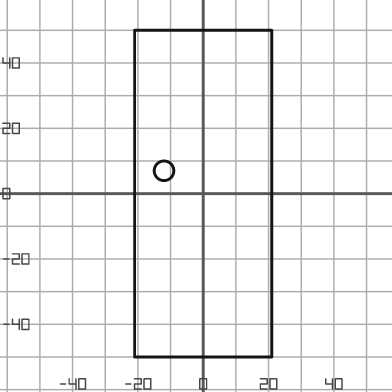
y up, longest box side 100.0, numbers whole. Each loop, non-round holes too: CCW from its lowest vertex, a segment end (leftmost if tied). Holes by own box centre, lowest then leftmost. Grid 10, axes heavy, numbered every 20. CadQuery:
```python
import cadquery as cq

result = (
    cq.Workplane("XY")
    .moveTo(-21.0, -50.0)
    .lineTo(21.0, -50.0)
    .lineTo(21.0, 50.0)
    .lineTo(-21.0, 50.0)
    .close()
    .moveTo(-12.0, 7.0)
    .circle(3.0)
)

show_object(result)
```